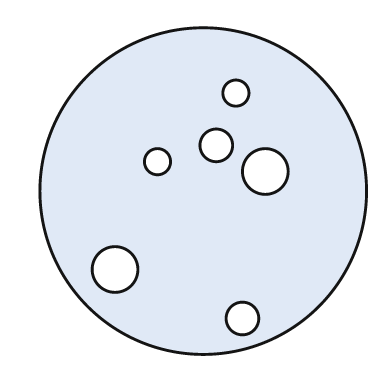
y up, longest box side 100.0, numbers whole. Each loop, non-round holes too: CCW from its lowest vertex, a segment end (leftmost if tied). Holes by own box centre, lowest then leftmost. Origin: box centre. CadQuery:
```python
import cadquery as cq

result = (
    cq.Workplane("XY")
    .moveTo(0.0, 0.0)
    .circle(50.0)
    .moveTo(12.0, -39.0)
    .circle(5.0)
    .moveTo(-27.0, -24.0)
    .circle(7.0)
    .moveTo(19.0, 6.0)
    .circle(7.0)
    .moveTo(-14.0, 9.0)
    .circle(4.0)
    .moveTo(4.0, 14.0)
    .circle(5.0)
    .moveTo(10.0, 30.0)
    .circle(4.0)
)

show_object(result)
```